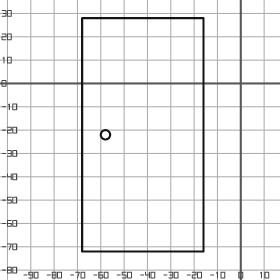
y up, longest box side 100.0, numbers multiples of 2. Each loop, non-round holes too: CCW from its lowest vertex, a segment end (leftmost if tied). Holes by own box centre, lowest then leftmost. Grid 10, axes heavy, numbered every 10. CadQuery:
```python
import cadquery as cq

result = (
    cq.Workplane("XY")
    .moveTo(-68.0, -72.0)
    .lineTo(-16.0, -72.0)
    .lineTo(-16.0, 28.0)
    .lineTo(-68.0, 28.0)
    .close()
    .moveTo(-58.0, -22.0)
    .circle(2.0)
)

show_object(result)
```